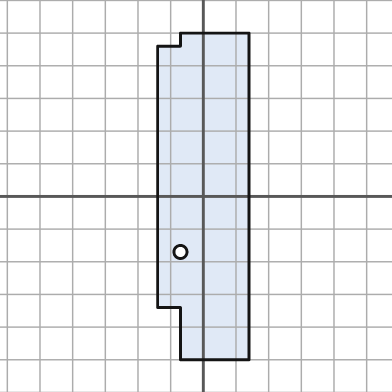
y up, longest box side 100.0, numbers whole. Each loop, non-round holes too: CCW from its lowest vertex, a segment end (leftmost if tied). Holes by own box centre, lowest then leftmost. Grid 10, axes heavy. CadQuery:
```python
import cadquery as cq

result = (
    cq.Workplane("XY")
    .moveTo(-7.0, -50.0)
    .lineTo(14.0, -50.0)
    .lineTo(14.0, 50.0)
    .lineTo(-7.0, 50.0)
    .lineTo(-7.0, 46.0)
    .lineTo(-14.0, 46.0)
    .lineTo(-14.0, -34.0)
    .lineTo(-7.0, -34.0)
    .close()
    .moveTo(-7.0, -17.0)
    .circle(2.0)
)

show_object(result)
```